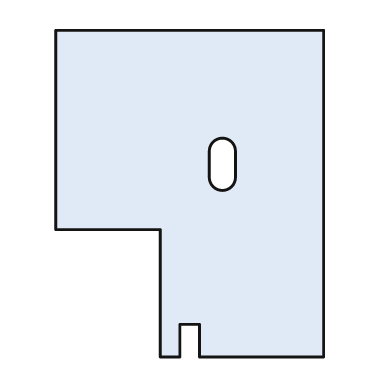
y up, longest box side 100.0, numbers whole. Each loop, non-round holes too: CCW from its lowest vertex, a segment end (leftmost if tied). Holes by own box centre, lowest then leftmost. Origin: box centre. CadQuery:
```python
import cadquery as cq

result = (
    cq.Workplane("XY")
    .moveTo(-9.0, -50.0)
    .lineTo(-3.0, -50.0)
    .lineTo(-3.0, -40.0)
    .lineTo(3.0, -40.0)
    .lineTo(3.0, -50.0)
    .lineTo(41.0, -50.0)
    .lineTo(41.0, 50.0)
    .lineTo(-41.0, 50.0)
    .lineTo(-41.0, -11.0)
    .lineTo(-9.0, -11.0)
    .close()
    .moveTo(6.0, 5.0)
    .threePointArc((10.0, 1.0), (14.0, 5.0))
    .lineTo(14.0, 13.0)
    .threePointArc((10.0, 17.0), (6.0, 13.0))
    .close()
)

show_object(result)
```